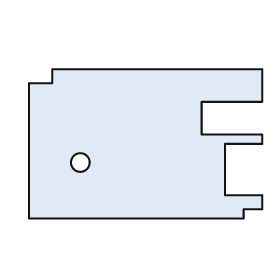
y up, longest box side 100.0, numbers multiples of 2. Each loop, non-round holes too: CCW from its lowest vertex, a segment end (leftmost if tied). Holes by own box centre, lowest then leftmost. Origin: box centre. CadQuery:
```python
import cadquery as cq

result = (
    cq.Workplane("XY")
    .moveTo(-50.0, -32.0)
    .lineTo(42.0, -32.0)
    .lineTo(42.0, -28.0)
    .lineTo(50.0, -28.0)
    .lineTo(50.0, -22.0)
    .lineTo(34.0, -22.0)
    .lineTo(34.0, 0.0)
    .lineTo(50.0, 0.0)
    .lineTo(50.0, 4.0)
    .lineTo(24.0, 4.0)
    .lineTo(24.0, 18.0)
    .lineTo(50.0, 18.0)
    .lineTo(50.0, 32.0)
    .lineTo(-40.0, 32.0)
    .lineTo(-40.0, 26.0)
    .lineTo(-50.0, 26.0)
    .close()
    .moveTo(-28.0, -8.0)
    .circle(4.0)
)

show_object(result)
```